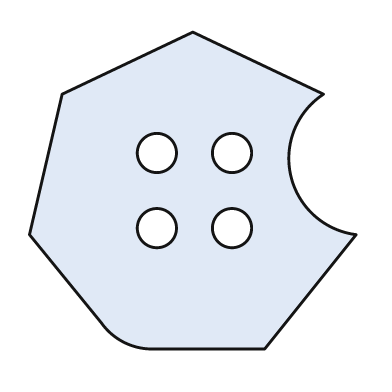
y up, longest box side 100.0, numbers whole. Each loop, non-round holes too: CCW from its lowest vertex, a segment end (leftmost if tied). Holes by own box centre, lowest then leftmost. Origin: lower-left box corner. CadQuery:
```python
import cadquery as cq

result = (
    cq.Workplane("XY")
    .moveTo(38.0, 0.0)
    .lineTo(72.0, 0.0)
    .lineTo(100.0, 35.0)
    .threePointArc((80.0, 53.0), (90.0, 78.0))
    .lineTo(50.0, 97.0)
    .lineTo(10.0, 78.0)
    .lineTo(0.0, 35.0)
    .lineTo(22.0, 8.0)
    .threePointArc((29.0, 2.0), (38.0, 0.0))
    .close()
    .moveTo(39.0, 37.0)
    .circle(6.0)
    .moveTo(62.0, 37.0)
    .circle(6.0)
    .moveTo(39.0, 60.0)
    .circle(6.0)
    .moveTo(62.0, 60.0)
    .circle(6.0)
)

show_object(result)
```